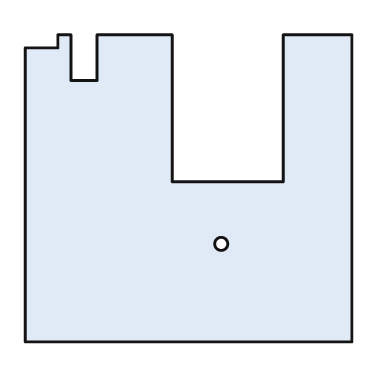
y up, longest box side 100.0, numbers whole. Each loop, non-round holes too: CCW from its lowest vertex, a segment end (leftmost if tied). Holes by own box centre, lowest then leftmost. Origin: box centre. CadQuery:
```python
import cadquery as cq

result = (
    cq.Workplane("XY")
    .moveTo(-50.0, -47.0)
    .lineTo(50.0, -47.0)
    .lineTo(50.0, 47.0)
    .lineTo(29.0, 47.0)
    .lineTo(29.0, 2.0)
    .lineTo(-5.0, 2.0)
    .lineTo(-5.0, 47.0)
    .lineTo(-28.0, 47.0)
    .lineTo(-28.0, 33.0)
    .lineTo(-36.0, 33.0)
    .lineTo(-36.0, 47.0)
    .lineTo(-40.0, 47.0)
    .lineTo(-40.0, 43.0)
    .lineTo(-50.0, 43.0)
    .close()
    .moveTo(10.0, -17.0)
    .circle(2.0)
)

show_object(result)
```